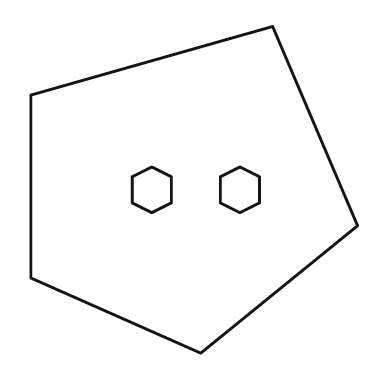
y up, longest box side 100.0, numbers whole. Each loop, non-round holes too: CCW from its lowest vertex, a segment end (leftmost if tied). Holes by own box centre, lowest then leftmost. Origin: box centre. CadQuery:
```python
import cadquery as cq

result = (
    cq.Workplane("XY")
    .moveTo(2.0, -50.0)
    .lineTo(50.0, -11.0)
    .lineTo(24.0, 50.0)
    .lineTo(-50.0, 29.0)
    .lineTo(-50.0, -27.0)
    .close()
    .moveTo(-13.0, -7.0)
    .lineTo(-7.0, -4.0)
    .lineTo(-7.0, 4.0)
    .lineTo(-13.0, 7.0)
    .lineTo(-19.0, 4.0)
    .lineTo(-19.0, -4.0)
    .close()
    .moveTo(14.0, -7.0)
    .lineTo(20.0, -4.0)
    .lineTo(20.0, 4.0)
    .lineTo(14.0, 7.0)
    .lineTo(8.0, 4.0)
    .lineTo(8.0, -4.0)
    .close()
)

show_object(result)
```